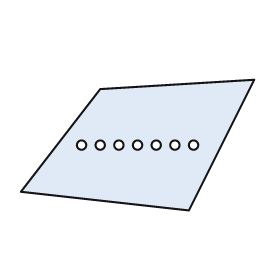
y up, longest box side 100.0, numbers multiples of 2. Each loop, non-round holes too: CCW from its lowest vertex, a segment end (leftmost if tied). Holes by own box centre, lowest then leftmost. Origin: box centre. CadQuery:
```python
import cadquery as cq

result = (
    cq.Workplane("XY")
    .moveTo(22.0, -28.0)
    .lineTo(50.0, 28.0)
    .lineTo(-16.0, 24.0)
    .lineTo(-50.0, -20.0)
    .close()
    .moveTo(-24.0, 0.0)
    .circle(2.0)
    .moveTo(-16.0, 0.0)
    .circle(2.0)
    .moveTo(-8.0, 0.0)
    .circle(2.0)
    .moveTo(0.0, 0.0)
    .circle(2.0)
    .moveTo(8.0, 0.0)
    .circle(2.0)
    .moveTo(16.0, 0.0)
    .circle(2.0)
    .moveTo(24.0, 0.0)
    .circle(2.0)
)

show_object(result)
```